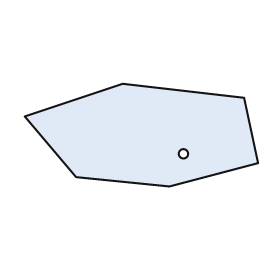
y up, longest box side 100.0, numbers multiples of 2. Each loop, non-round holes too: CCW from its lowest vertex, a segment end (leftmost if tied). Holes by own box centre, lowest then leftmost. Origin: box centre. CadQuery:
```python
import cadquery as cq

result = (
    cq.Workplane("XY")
    .moveTo(12.0, -22.0)
    .lineTo(50.0, -12.0)
    .lineTo(44.0, 16.0)
    .lineTo(-8.0, 22.0)
    .lineTo(-50.0, 8.0)
    .lineTo(-28.0, -18.0)
    .close()
    .moveTo(18.0, -8.0)
    .circle(2.0)
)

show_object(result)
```